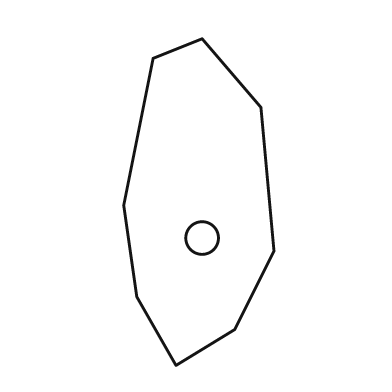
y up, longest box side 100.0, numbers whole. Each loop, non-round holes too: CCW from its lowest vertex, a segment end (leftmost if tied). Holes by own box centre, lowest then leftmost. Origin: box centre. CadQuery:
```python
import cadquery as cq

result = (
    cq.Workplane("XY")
    .moveTo(-7.0, -50.0)
    .lineTo(11.0, -39.0)
    .lineTo(23.0, -15.0)
    .lineTo(19.0, 29.0)
    .lineTo(1.0, 50.0)
    .lineTo(-14.0, 44.0)
    .lineTo(-23.0, -1.0)
    .lineTo(-19.0, -29.0)
    .close()
    .moveTo(1.0, -11.0)
    .circle(5.0)
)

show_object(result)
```